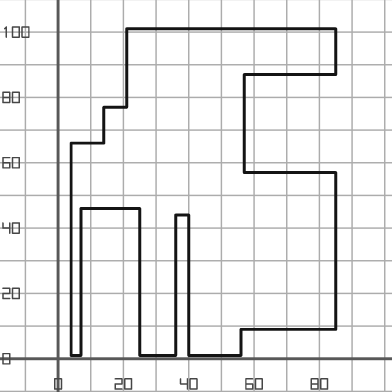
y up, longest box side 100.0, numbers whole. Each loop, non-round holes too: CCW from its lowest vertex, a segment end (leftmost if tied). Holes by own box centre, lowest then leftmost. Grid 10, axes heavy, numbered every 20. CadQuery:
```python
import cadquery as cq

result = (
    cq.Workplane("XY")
    .moveTo(4.0, 1.0)
    .lineTo(7.0, 1.0)
    .lineTo(7.0, 46.0)
    .lineTo(25.0, 46.0)
    .lineTo(25.0, 1.0)
    .lineTo(36.0, 1.0)
    .lineTo(36.0, 44.0)
    .lineTo(40.0, 44.0)
    .lineTo(40.0, 1.0)
    .lineTo(56.0, 1.0)
    .lineTo(56.0, 9.0)
    .lineTo(85.0, 9.0)
    .lineTo(85.0, 57.0)
    .lineTo(57.0, 57.0)
    .lineTo(57.0, 87.0)
    .lineTo(85.0, 87.0)
    .lineTo(85.0, 101.0)
    .lineTo(21.0, 101.0)
    .lineTo(21.0, 77.0)
    .lineTo(14.0, 77.0)
    .lineTo(14.0, 66.0)
    .lineTo(4.0, 66.0)
    .close()
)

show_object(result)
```